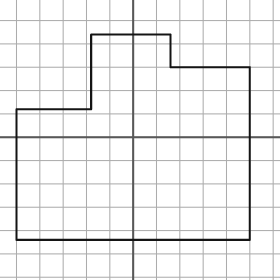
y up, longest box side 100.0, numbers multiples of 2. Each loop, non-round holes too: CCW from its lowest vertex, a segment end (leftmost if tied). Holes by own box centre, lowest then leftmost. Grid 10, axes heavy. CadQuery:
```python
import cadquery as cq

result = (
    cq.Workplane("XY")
    .moveTo(-50.0, -44.0)
    .lineTo(50.0, -44.0)
    .lineTo(50.0, 30.0)
    .lineTo(16.0, 30.0)
    .lineTo(16.0, 44.0)
    .lineTo(-18.0, 44.0)
    .lineTo(-18.0, 12.0)
    .lineTo(-50.0, 12.0)
    .close()
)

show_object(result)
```